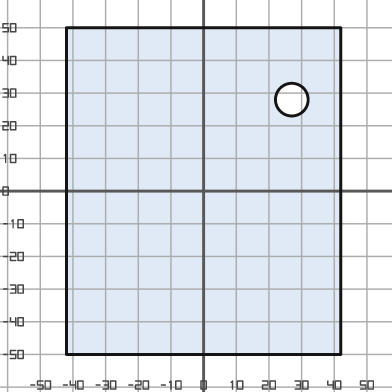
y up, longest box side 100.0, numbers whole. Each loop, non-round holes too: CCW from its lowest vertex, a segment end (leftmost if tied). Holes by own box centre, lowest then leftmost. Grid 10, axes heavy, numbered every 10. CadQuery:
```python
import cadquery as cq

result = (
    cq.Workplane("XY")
    .moveTo(-42.0, -50.0)
    .lineTo(42.0, -50.0)
    .lineTo(42.0, 50.0)
    .lineTo(-42.0, 50.0)
    .close()
    .moveTo(27.0, 28.0)
    .circle(5.0)
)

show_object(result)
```